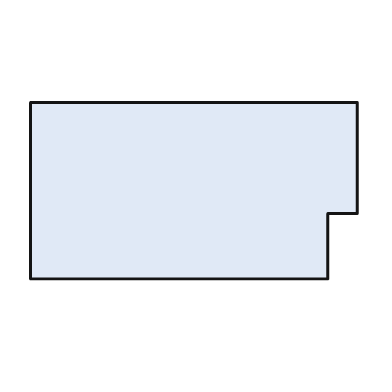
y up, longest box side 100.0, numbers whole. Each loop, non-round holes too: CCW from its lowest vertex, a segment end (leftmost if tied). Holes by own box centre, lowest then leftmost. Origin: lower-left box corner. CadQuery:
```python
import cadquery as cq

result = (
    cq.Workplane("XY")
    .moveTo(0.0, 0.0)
    .lineTo(91.0, 0.0)
    .lineTo(91.0, 20.0)
    .lineTo(100.0, 20.0)
    .lineTo(100.0, 54.0)
    .lineTo(0.0, 54.0)
    .close()
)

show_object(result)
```